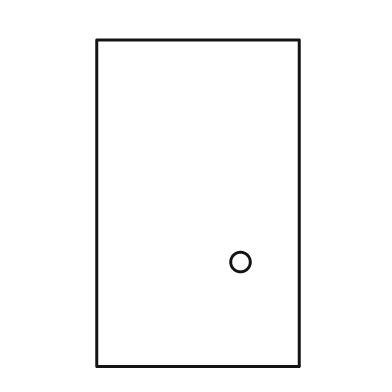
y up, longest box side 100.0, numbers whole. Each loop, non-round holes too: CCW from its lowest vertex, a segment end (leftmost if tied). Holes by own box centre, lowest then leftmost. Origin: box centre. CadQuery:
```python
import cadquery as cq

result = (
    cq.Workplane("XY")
    .moveTo(-31.0, -50.0)
    .lineTo(31.0, -50.0)
    .lineTo(31.0, 50.0)
    .lineTo(-31.0, 50.0)
    .close()
    .moveTo(13.0, -18.0)
    .circle(3.0)
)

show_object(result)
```